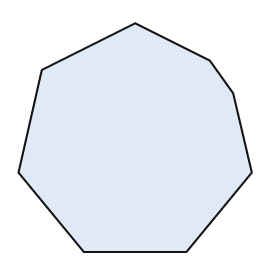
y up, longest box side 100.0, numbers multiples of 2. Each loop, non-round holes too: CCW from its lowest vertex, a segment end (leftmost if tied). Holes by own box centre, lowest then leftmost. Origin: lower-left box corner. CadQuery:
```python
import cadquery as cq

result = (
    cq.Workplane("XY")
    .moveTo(28.0, 0.0)
    .lineTo(72.0, 0.0)
    .lineTo(100.0, 34.0)
    .lineTo(92.0, 68.0)
    .lineTo(82.0, 82.0)
    .lineTo(50.0, 98.0)
    .lineTo(10.0, 78.0)
    .lineTo(0.0, 34.0)
    .close()
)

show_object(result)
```